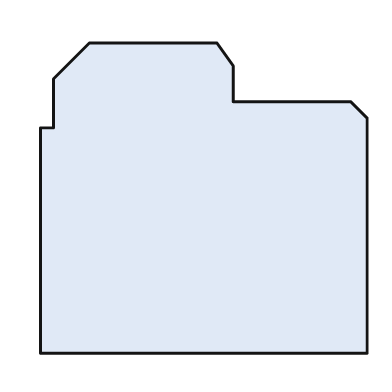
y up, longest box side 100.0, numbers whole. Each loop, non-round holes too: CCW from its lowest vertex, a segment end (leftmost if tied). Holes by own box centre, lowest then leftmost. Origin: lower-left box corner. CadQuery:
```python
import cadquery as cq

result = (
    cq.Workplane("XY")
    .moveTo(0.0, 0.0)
    .lineTo(100.0, 0.0)
    .lineTo(100.0, 72.0)
    .lineTo(95.0, 77.0)
    .lineTo(59.0, 77.0)
    .lineTo(59.0, 88.0)
    .lineTo(54.0, 95.0)
    .lineTo(15.0, 95.0)
    .lineTo(4.0, 84.0)
    .lineTo(4.0, 69.0)
    .lineTo(0.0, 69.0)
    .close()
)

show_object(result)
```